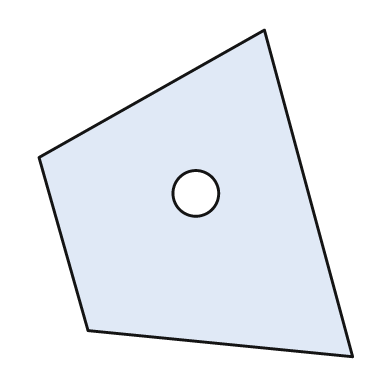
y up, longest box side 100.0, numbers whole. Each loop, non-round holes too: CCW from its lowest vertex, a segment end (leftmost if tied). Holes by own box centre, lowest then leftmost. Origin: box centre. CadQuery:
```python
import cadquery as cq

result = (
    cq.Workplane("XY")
    .moveTo(48.0, -50.0)
    .lineTo(21.0, 50.0)
    .lineTo(-48.0, 11.0)
    .lineTo(-33.0, -42.0)
    .close()
    .moveTo(0.0, 0.0)
    .circle(7.0)
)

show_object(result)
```